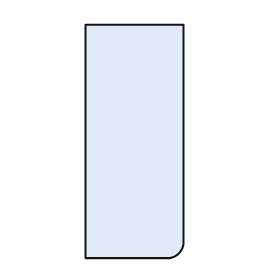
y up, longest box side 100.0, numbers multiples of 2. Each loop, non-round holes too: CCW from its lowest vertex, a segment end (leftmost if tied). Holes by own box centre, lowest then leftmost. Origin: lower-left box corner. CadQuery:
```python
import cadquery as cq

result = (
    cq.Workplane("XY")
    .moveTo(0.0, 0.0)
    .lineTo(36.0, 0.0)
    .threePointArc((40.0, 2.0), (42.0, 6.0))
    .lineTo(42.0, 100.0)
    .lineTo(0.0, 100.0)
    .close()
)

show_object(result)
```